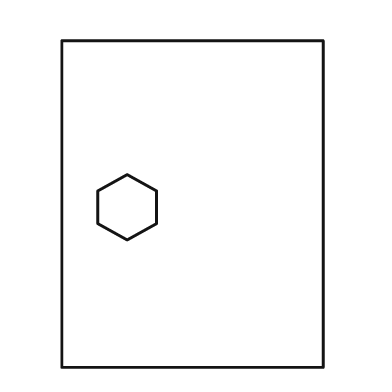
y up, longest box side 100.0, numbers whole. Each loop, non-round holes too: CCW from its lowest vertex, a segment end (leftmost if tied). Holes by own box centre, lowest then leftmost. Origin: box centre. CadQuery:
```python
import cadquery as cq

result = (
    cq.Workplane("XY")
    .moveTo(-40.0, -50.0)
    .lineTo(40.0, -50.0)
    .lineTo(40.0, 50.0)
    .lineTo(-40.0, 50.0)
    .close()
    .moveTo(-20.0, -11.0)
    .lineTo(-11.0, -6.0)
    .lineTo(-11.0, 4.0)
    .lineTo(-20.0, 9.0)
    .lineTo(-29.0, 4.0)
    .lineTo(-29.0, -6.0)
    .close()
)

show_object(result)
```